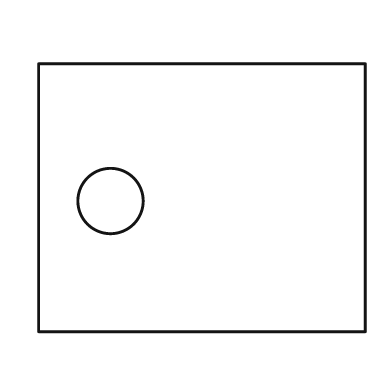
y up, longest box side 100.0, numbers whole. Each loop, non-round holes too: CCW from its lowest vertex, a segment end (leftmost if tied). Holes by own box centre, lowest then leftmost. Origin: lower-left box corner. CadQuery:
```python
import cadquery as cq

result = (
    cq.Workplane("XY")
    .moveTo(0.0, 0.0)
    .lineTo(100.0, 0.0)
    .lineTo(100.0, 82.0)
    .lineTo(0.0, 82.0)
    .close()
    .moveTo(22.0, 40.0)
    .circle(10.0)
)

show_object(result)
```